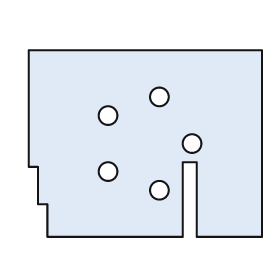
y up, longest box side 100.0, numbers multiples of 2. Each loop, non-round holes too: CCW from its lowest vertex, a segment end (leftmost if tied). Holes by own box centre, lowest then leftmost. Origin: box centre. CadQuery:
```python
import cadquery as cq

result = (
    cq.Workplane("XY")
    .moveTo(-42.0, -40.0)
    .lineTo(16.0, -40.0)
    .lineTo(16.0, -8.0)
    .lineTo(22.0, -8.0)
    .lineTo(22.0, -40.0)
    .lineTo(50.0, -40.0)
    .lineTo(50.0, 40.0)
    .lineTo(-50.0, 40.0)
    .lineTo(-50.0, -10.0)
    .lineTo(-46.0, -10.0)
    .lineTo(-46.0, -26.0)
    .lineTo(-42.0, -26.0)
    .close()
    .moveTo(6.0, -20.0)
    .circle(4.0)
    .moveTo(-16.0, -12.0)
    .circle(4.0)
    .moveTo(20.0, 0.0)
    .circle(4.0)
    .moveTo(-16.0, 12.0)
    .circle(4.0)
    .moveTo(6.0, 20.0)
    .circle(4.0)
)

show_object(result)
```